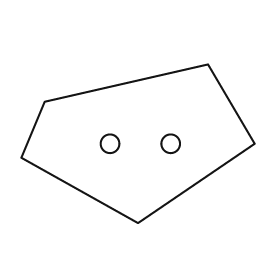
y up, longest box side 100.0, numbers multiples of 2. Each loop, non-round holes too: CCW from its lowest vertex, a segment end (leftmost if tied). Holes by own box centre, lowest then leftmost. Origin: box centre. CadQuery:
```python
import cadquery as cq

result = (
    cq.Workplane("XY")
    .moveTo(0.0, -34.0)
    .lineTo(50.0, 0.0)
    .lineTo(30.0, 34.0)
    .lineTo(-40.0, 18.0)
    .lineTo(-50.0, -6.0)
    .close()
    .moveTo(-12.0, 0.0)
    .circle(4.0)
    .moveTo(14.0, 0.0)
    .circle(4.0)
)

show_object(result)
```